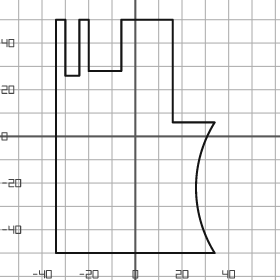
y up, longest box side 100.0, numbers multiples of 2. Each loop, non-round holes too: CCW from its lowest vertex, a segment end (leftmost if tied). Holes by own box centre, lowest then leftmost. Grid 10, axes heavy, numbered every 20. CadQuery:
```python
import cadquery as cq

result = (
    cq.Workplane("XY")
    .moveTo(-34.0, -50.0)
    .lineTo(34.0, -50.0)
    .threePointArc((26.0, -22.0), (34.0, 6.0))
    .lineTo(16.0, 6.0)
    .lineTo(16.0, 50.0)
    .lineTo(-6.0, 50.0)
    .lineTo(-6.0, 28.0)
    .lineTo(-20.0, 28.0)
    .lineTo(-20.0, 50.0)
    .lineTo(-24.0, 50.0)
    .lineTo(-24.0, 26.0)
    .lineTo(-30.0, 26.0)
    .lineTo(-30.0, 50.0)
    .lineTo(-34.0, 50.0)
    .close()
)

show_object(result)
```